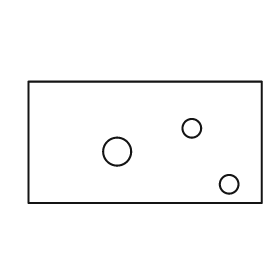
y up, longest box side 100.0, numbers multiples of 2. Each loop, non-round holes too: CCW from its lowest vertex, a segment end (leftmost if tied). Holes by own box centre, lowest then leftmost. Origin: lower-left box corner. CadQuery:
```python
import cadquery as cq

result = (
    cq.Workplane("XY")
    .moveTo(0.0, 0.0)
    .lineTo(100.0, 0.0)
    .lineTo(100.0, 52.0)
    .lineTo(0.0, 52.0)
    .close()
    .moveTo(86.0, 8.0)
    .circle(4.0)
    .moveTo(38.0, 22.0)
    .circle(6.0)
    .moveTo(70.0, 32.0)
    .circle(4.0)
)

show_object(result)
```